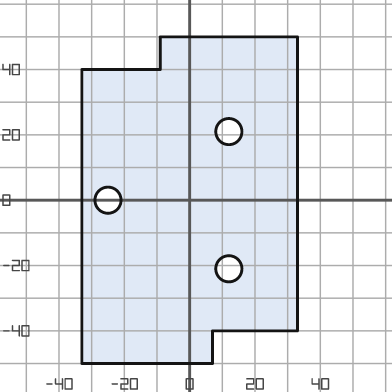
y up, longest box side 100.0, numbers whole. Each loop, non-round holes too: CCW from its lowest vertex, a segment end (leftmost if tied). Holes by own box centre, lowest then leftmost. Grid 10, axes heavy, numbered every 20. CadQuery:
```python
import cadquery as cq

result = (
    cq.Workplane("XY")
    .moveTo(-33.0, -50.0)
    .lineTo(7.0, -50.0)
    .lineTo(7.0, -40.0)
    .lineTo(33.0, -40.0)
    .lineTo(33.0, 50.0)
    .lineTo(-9.0, 50.0)
    .lineTo(-9.0, 40.0)
    .lineTo(-33.0, 40.0)
    .close()
    .moveTo(12.0, -21.0)
    .circle(4.0)
    .moveTo(-25.0, 0.0)
    .circle(4.0)
    .moveTo(12.0, 21.0)
    .circle(4.0)
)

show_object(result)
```